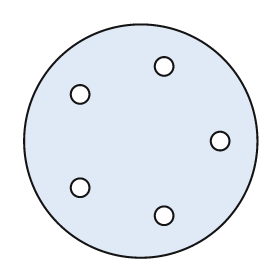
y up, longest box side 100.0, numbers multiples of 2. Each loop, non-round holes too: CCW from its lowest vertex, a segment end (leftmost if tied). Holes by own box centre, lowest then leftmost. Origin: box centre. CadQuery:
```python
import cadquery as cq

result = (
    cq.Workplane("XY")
    .moveTo(0.0, 0.0)
    .circle(50.0)
    .moveTo(10.0, -32.0)
    .circle(4.0)
    .moveTo(-26.0, -20.0)
    .circle(4.0)
    .moveTo(34.0, 0.0)
    .circle(4.0)
    .moveTo(-26.0, 20.0)
    .circle(4.0)
    .moveTo(10.0, 32.0)
    .circle(4.0)
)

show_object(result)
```